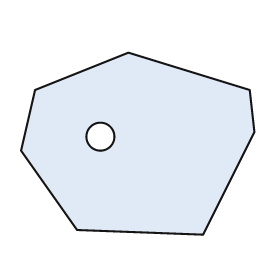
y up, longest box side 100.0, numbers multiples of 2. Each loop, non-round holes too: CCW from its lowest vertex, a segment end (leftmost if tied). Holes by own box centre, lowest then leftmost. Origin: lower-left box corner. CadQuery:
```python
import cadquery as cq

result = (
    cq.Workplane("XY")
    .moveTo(78.0, 0.0)
    .lineTo(100.0, 44.0)
    .lineTo(98.0, 62.0)
    .lineTo(46.0, 78.0)
    .lineTo(6.0, 62.0)
    .lineTo(0.0, 36.0)
    .lineTo(24.0, 2.0)
    .close()
    .moveTo(34.0, 42.0)
    .circle(6.0)
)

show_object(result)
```